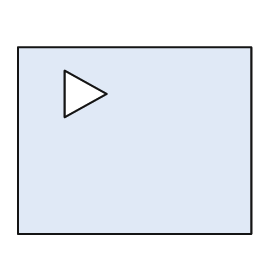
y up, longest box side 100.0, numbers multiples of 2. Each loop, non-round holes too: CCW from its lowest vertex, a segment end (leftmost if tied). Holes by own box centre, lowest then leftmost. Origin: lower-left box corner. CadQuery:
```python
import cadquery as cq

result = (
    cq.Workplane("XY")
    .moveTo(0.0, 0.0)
    .lineTo(100.0, 0.0)
    .lineTo(100.0, 80.0)
    .lineTo(0.0, 80.0)
    .close()
    .moveTo(20.0, 50.0)
    .lineTo(38.0, 60.0)
    .lineTo(20.0, 70.0)
    .close()
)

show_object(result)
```